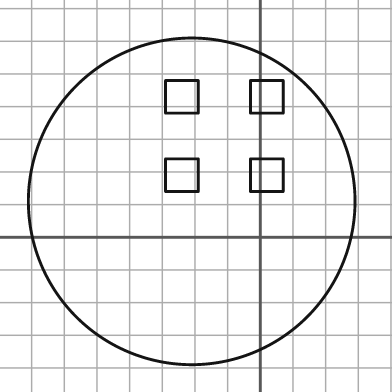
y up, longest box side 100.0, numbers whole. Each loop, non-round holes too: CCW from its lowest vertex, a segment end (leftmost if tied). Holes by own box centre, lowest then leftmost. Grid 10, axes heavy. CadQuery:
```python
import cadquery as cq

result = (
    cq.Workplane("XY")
    .moveTo(-21.0, 11.0)
    .circle(50.0)
    .moveTo(-29.0, 14.0)
    .lineTo(-19.0, 14.0)
    .lineTo(-19.0, 24.0)
    .lineTo(-29.0, 24.0)
    .close()
    .moveTo(-3.0, 14.0)
    .lineTo(7.0, 14.0)
    .lineTo(7.0, 24.0)
    .lineTo(-3.0, 24.0)
    .close()
    .moveTo(-29.0, 38.0)
    .lineTo(-19.0, 38.0)
    .lineTo(-19.0, 48.0)
    .lineTo(-29.0, 48.0)
    .close()
    .moveTo(-3.0, 38.0)
    .lineTo(7.0, 38.0)
    .lineTo(7.0, 48.0)
    .lineTo(-3.0, 48.0)
    .close()
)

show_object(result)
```